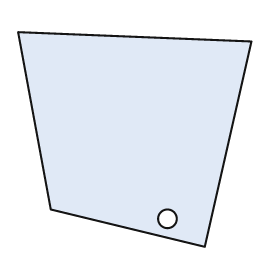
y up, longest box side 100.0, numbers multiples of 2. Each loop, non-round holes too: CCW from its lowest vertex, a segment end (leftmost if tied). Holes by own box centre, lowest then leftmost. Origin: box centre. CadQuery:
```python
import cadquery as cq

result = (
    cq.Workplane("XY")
    .moveTo(30.0, -46.0)
    .lineTo(50.0, 42.0)
    .lineTo(-50.0, 46.0)
    .lineTo(-36.0, -30.0)
    .close()
    .moveTo(14.0, -34.0)
    .circle(4.0)
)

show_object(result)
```